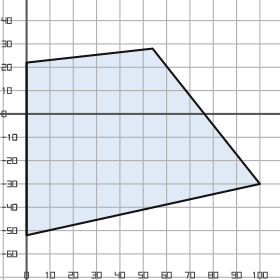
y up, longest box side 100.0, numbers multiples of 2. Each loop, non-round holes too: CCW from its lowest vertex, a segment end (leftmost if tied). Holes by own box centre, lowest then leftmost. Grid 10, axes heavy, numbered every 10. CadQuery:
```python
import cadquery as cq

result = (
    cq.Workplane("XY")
    .moveTo(0.0, -52.0)
    .lineTo(100.0, -30.0)
    .lineTo(54.0, 28.0)
    .lineTo(0.0, 22.0)
    .close()
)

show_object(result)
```